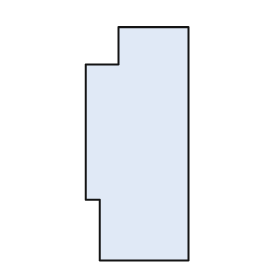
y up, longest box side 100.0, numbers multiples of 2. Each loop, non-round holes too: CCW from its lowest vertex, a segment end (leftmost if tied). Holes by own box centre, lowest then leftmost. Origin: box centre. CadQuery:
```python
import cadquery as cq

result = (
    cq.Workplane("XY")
    .moveTo(-16.0, -50.0)
    .lineTo(22.0, -50.0)
    .lineTo(22.0, 50.0)
    .lineTo(-8.0, 50.0)
    .lineTo(-8.0, 34.0)
    .lineTo(-22.0, 34.0)
    .lineTo(-22.0, -24.0)
    .lineTo(-16.0, -24.0)
    .close()
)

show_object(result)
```